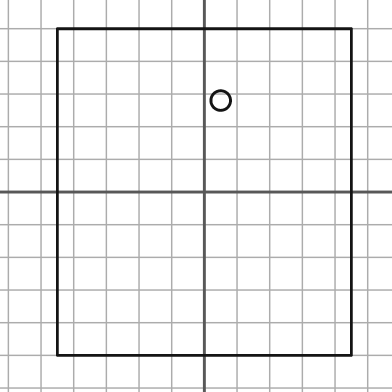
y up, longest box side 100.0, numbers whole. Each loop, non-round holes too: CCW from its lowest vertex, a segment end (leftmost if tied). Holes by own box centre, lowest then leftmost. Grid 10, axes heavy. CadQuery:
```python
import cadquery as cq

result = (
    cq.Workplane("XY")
    .moveTo(-45.0, -50.0)
    .lineTo(45.0, -50.0)
    .lineTo(45.0, 50.0)
    .lineTo(-45.0, 50.0)
    .close()
    .moveTo(5.0, 28.0)
    .circle(3.0)
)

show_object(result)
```